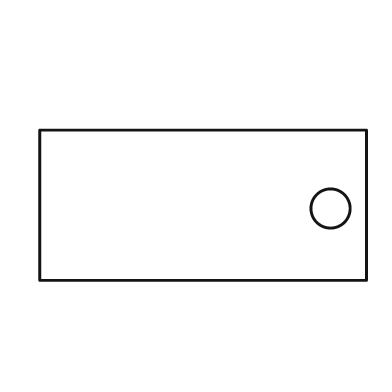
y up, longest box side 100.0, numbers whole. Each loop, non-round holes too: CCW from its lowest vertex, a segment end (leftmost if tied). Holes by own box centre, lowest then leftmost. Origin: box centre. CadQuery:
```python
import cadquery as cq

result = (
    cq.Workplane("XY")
    .moveTo(-50.0, -23.0)
    .lineTo(50.0, -23.0)
    .lineTo(50.0, 23.0)
    .lineTo(-50.0, 23.0)
    .close()
    .moveTo(39.0, -1.0)
    .circle(6.0)
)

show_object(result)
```